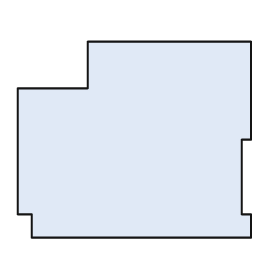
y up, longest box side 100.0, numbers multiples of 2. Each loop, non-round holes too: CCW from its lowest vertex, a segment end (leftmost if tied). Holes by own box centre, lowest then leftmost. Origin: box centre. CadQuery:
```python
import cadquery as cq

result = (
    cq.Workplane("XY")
    .moveTo(-44.0, -42.0)
    .lineTo(50.0, -42.0)
    .lineTo(50.0, -32.0)
    .lineTo(46.0, -32.0)
    .lineTo(46.0, 0.0)
    .lineTo(50.0, 0.0)
    .lineTo(50.0, 42.0)
    .lineTo(-20.0, 42.0)
    .lineTo(-20.0, 22.0)
    .lineTo(-50.0, 22.0)
    .lineTo(-50.0, -32.0)
    .lineTo(-44.0, -32.0)
    .close()
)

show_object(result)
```